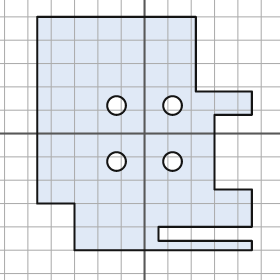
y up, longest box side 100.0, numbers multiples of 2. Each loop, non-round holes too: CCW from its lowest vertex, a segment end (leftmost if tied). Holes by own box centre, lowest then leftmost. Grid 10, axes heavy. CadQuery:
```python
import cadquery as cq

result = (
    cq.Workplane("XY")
    .moveTo(-30.0, -50.0)
    .lineTo(46.0, -50.0)
    .lineTo(46.0, -46.0)
    .lineTo(6.0, -46.0)
    .lineTo(6.0, -40.0)
    .lineTo(46.0, -40.0)
    .lineTo(46.0, -24.0)
    .lineTo(30.0, -24.0)
    .lineTo(30.0, 8.0)
    .lineTo(46.0, 8.0)
    .lineTo(46.0, 18.0)
    .lineTo(22.0, 18.0)
    .lineTo(22.0, 50.0)
    .lineTo(-46.0, 50.0)
    .lineTo(-46.0, -30.0)
    .lineTo(-30.0, -30.0)
    .close()
    .moveTo(-12.0, -12.0)
    .circle(4.0)
    .moveTo(12.0, -12.0)
    .circle(4.0)
    .moveTo(-12.0, 12.0)
    .circle(4.0)
    .moveTo(12.0, 12.0)
    .circle(4.0)
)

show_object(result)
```